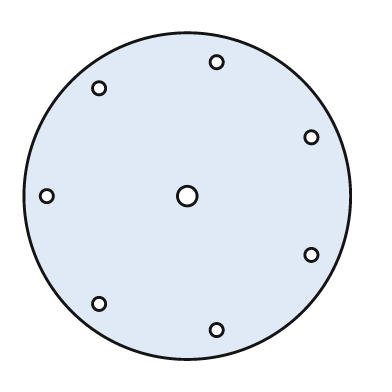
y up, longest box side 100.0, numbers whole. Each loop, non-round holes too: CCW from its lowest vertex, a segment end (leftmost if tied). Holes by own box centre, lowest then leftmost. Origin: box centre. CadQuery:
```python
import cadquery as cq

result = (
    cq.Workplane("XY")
    .moveTo(0.0, 0.0)
    .circle(50.0)
    .moveTo(9.0, -41.0)
    .circle(2.0)
    .moveTo(-27.0, -33.0)
    .circle(2.0)
    .moveTo(38.0, -18.0)
    .circle(2.0)
    .moveTo(-43.0, 0.0)
    .circle(2.0)
    .moveTo(0.0, 0.0)
    .circle(3.0)
    .moveTo(38.0, 18.0)
    .circle(2.0)
    .moveTo(-27.0, 33.0)
    .circle(2.0)
    .moveTo(9.0, 41.0)
    .circle(2.0)
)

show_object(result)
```